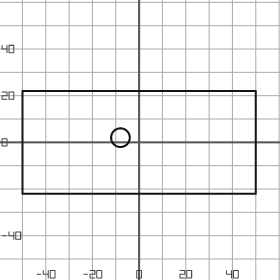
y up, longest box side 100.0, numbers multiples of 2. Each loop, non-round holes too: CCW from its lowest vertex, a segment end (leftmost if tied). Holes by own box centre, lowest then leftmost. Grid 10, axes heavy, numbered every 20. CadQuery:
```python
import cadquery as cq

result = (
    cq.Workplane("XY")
    .moveTo(-50.0, -22.0)
    .lineTo(50.0, -22.0)
    .lineTo(50.0, 22.0)
    .lineTo(-50.0, 22.0)
    .close()
    .moveTo(-8.0, 2.0)
    .circle(4.0)
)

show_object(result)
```